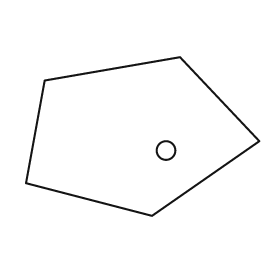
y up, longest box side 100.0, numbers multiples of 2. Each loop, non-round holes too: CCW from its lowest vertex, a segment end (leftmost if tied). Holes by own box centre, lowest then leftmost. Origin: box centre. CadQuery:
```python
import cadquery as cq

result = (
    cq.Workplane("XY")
    .moveTo(4.0, -34.0)
    .lineTo(50.0, -2.0)
    .lineTo(16.0, 34.0)
    .lineTo(-42.0, 24.0)
    .lineTo(-50.0, -20.0)
    .close()
    .moveTo(10.0, -6.0)
    .circle(4.0)
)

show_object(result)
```